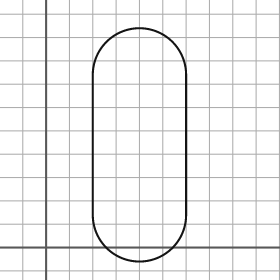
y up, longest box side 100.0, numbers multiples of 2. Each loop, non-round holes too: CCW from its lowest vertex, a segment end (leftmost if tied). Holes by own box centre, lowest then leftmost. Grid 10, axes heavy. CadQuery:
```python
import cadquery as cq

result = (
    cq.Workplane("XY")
    .moveTo(20.0, 14.0)
    .threePointArc((40.0, -6.0), (60.0, 14.0))
    .lineTo(60.0, 74.0)
    .threePointArc((40.0, 94.0), (20.0, 74.0))
    .close()
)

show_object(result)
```